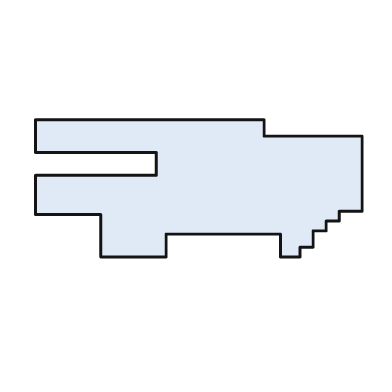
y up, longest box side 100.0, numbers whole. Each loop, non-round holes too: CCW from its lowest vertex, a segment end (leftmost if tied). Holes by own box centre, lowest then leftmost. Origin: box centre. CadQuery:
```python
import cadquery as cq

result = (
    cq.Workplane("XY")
    .moveTo(-30.0, -21.0)
    .lineTo(-10.0, -21.0)
    .lineTo(-10.0, -14.0)
    .lineTo(25.0, -14.0)
    .lineTo(25.0, -21.0)
    .lineTo(31.0, -21.0)
    .lineTo(31.0, -18.0)
    .lineTo(35.0, -18.0)
    .lineTo(35.0, -13.0)
    .lineTo(39.0, -13.0)
    .lineTo(39.0, -10.0)
    .lineTo(43.0, -10.0)
    .lineTo(43.0, -7.0)
    .lineTo(50.0, -7.0)
    .lineTo(50.0, 16.0)
    .lineTo(20.0, 16.0)
    .lineTo(20.0, 21.0)
    .lineTo(-50.0, 21.0)
    .lineTo(-50.0, 11.0)
    .lineTo(-13.0, 11.0)
    .lineTo(-13.0, 4.0)
    .lineTo(-50.0, 4.0)
    .lineTo(-50.0, -8.0)
    .lineTo(-30.0, -8.0)
    .close()
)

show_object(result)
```